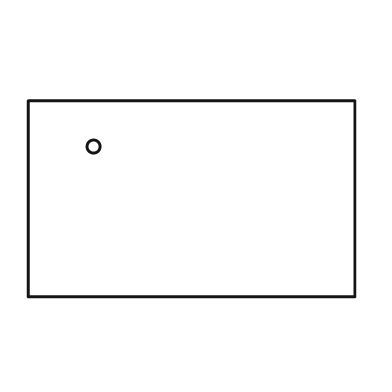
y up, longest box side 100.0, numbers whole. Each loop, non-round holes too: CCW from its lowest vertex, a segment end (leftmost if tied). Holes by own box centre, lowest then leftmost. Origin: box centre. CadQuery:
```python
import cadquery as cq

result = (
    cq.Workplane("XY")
    .moveTo(-50.0, -30.0)
    .lineTo(50.0, -30.0)
    .lineTo(50.0, 30.0)
    .lineTo(-50.0, 30.0)
    .close()
    .moveTo(-30.0, 16.0)
    .circle(2.0)
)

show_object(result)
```